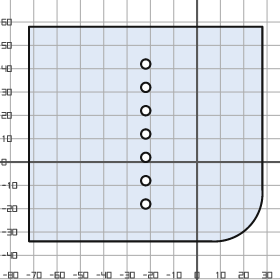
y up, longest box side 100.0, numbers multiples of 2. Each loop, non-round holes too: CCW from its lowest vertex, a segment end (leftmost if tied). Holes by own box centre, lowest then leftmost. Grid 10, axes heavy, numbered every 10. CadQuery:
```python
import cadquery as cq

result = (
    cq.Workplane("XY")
    .moveTo(-72.0, -34.0)
    .lineTo(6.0, -34.0)
    .threePointArc((22.0, -28.0), (28.0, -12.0))
    .lineTo(28.0, 58.0)
    .lineTo(-72.0, 58.0)
    .close()
    .moveTo(-22.0, -18.0)
    .circle(2.0)
    .moveTo(-22.0, -8.0)
    .circle(2.0)
    .moveTo(-22.0, 2.0)
    .circle(2.0)
    .moveTo(-22.0, 12.0)
    .circle(2.0)
    .moveTo(-22.0, 22.0)
    .circle(2.0)
    .moveTo(-22.0, 32.0)
    .circle(2.0)
    .moveTo(-22.0, 42.0)
    .circle(2.0)
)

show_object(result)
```